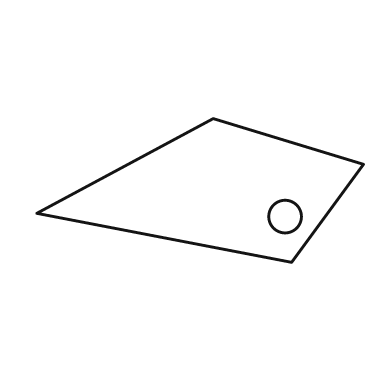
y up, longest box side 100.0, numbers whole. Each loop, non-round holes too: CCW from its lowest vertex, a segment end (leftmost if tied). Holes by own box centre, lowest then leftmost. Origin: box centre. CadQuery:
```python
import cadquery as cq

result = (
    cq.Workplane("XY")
    .moveTo(28.0, -22.0)
    .lineTo(50.0, 8.0)
    .lineTo(4.0, 22.0)
    .lineTo(-50.0, -7.0)
    .close()
    .moveTo(26.0, -8.0)
    .circle(5.0)
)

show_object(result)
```